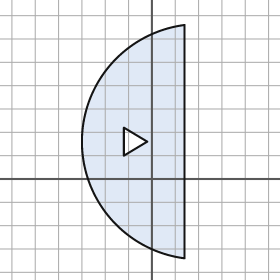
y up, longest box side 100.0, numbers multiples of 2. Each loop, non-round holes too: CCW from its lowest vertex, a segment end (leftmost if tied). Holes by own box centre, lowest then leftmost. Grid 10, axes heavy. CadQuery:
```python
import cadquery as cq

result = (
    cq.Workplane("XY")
    .moveTo(14.0, -34.0)
    .lineTo(14.0, 66.0)
    .threePointArc((-30.0, 16.0), (14.0, -34.0))
    .close()
    .moveTo(-12.0, 10.0)
    .lineTo(-2.0, 16.0)
    .lineTo(-12.0, 22.0)
    .close()
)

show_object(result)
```